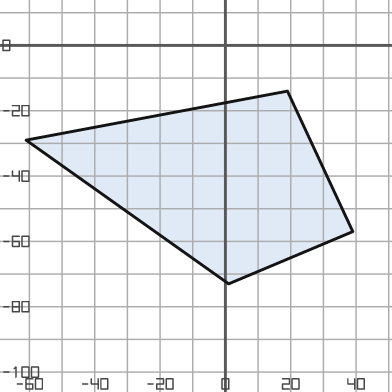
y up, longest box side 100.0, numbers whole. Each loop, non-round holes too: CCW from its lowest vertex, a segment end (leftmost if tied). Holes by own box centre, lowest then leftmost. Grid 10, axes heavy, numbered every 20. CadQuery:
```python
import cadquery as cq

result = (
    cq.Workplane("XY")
    .moveTo(1.0, -73.0)
    .lineTo(39.0, -57.0)
    .lineTo(19.0, -14.0)
    .lineTo(-61.0, -29.0)
    .close()
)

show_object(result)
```